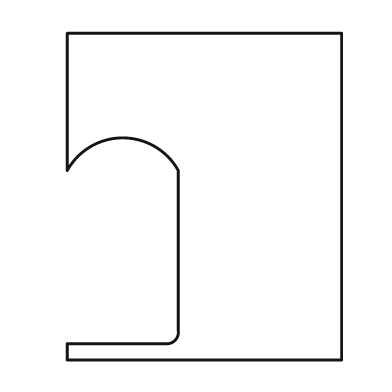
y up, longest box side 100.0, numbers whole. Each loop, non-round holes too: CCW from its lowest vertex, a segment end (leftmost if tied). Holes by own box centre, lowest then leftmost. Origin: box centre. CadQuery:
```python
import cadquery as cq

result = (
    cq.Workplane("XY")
    .moveTo(-42.0, -50.0)
    .lineTo(42.0, -50.0)
    .lineTo(42.0, 50.0)
    .lineTo(-42.0, 50.0)
    .lineTo(-42.0, 8.0)
    .threePointArc((-25.0, 18.0), (-8.0, 8.0))
    .lineTo(-8.0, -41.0)
    .threePointArc((-9.0, -44.0), (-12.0, -45.0))
    .lineTo(-42.0, -45.0)
    .close()
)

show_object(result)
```